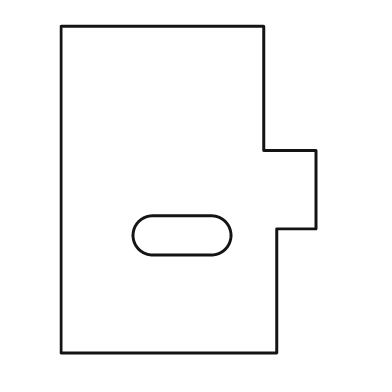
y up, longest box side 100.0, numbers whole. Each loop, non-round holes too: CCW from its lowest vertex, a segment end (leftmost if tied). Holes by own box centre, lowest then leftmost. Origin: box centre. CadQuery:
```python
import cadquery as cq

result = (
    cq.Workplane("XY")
    .moveTo(-39.0, -50.0)
    .lineTo(27.0, -50.0)
    .lineTo(27.0, -12.0)
    .lineTo(39.0, -12.0)
    .lineTo(39.0, 12.0)
    .lineTo(23.0, 12.0)
    .lineTo(23.0, 50.0)
    .lineTo(-39.0, 50.0)
    .close()
    .moveTo(-11.0, -20.0)
    .lineTo(7.0, -20.0)
    .threePointArc((13.0, -14.0), (7.0, -8.0))
    .lineTo(-11.0, -8.0)
    .threePointArc((-17.0, -14.0), (-11.0, -20.0))
    .close()
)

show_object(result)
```